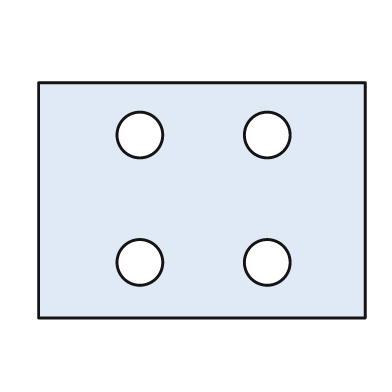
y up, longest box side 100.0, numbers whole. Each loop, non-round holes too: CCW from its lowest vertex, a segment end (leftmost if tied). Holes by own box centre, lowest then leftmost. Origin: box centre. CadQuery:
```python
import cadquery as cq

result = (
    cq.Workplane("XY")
    .moveTo(-50.0, -36.0)
    .lineTo(50.0, -36.0)
    .lineTo(50.0, 36.0)
    .lineTo(-50.0, 36.0)
    .close()
    .moveTo(-19.0, -19.0)
    .circle(7.0)
    .moveTo(20.0, -19.0)
    .circle(7.0)
    .moveTo(-19.0, 20.0)
    .circle(7.0)
    .moveTo(20.0, 20.0)
    .circle(7.0)
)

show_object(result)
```